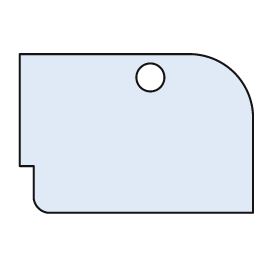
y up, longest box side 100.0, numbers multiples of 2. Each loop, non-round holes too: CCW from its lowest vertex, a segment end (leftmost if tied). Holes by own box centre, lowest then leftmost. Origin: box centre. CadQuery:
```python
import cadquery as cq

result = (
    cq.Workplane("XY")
    .moveTo(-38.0, -34.0)
    .lineTo(50.0, -34.0)
    .lineTo(50.0, 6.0)
    .threePointArc((42.0, 26.0), (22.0, 34.0))
    .lineTo(-50.0, 34.0)
    .lineTo(-50.0, -14.0)
    .lineTo(-44.0, -14.0)
    .lineTo(-44.0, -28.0)
    .threePointArc((-42.0, -32.0), (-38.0, -34.0))
    .close()
    .moveTo(6.0, 24.0)
    .circle(6.0)
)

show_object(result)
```